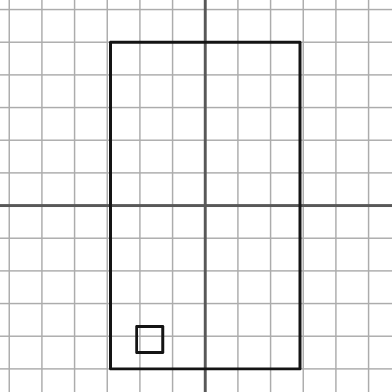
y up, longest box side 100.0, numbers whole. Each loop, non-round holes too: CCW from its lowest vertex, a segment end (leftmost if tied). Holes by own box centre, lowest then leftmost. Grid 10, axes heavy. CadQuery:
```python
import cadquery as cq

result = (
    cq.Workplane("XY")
    .moveTo(-29.0, -50.0)
    .lineTo(29.0, -50.0)
    .lineTo(29.0, 50.0)
    .lineTo(-29.0, 50.0)
    .close()
    .moveTo(-21.0, -45.0)
    .lineTo(-13.0, -45.0)
    .lineTo(-13.0, -37.0)
    .lineTo(-21.0, -37.0)
    .close()
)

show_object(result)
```